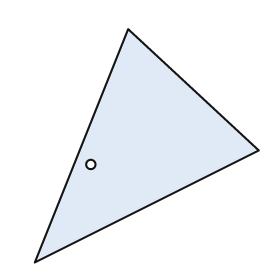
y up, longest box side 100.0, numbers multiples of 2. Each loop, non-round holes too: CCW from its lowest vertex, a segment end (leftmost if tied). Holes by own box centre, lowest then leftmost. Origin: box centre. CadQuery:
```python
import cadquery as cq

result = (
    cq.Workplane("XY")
    .moveTo(-48.0, -50.0)
    .lineTo(48.0, -2.0)
    .lineTo(-8.0, 50.0)
    .close()
    .moveTo(-24.0, -8.0)
    .circle(2.0)
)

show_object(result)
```